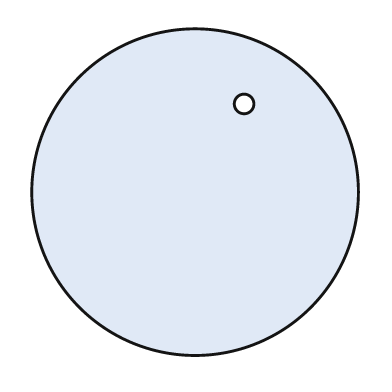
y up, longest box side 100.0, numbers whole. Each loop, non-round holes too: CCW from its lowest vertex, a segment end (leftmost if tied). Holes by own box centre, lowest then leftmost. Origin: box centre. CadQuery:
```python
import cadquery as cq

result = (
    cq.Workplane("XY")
    .moveTo(0.0, 0.0)
    .circle(50.0)
    .moveTo(15.0, 27.0)
    .circle(3.0)
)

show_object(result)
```